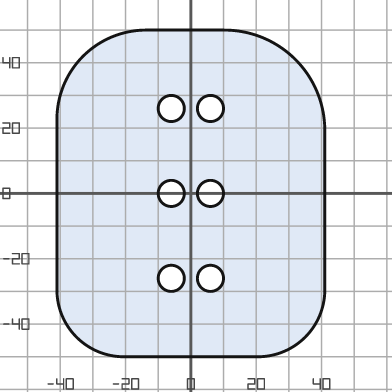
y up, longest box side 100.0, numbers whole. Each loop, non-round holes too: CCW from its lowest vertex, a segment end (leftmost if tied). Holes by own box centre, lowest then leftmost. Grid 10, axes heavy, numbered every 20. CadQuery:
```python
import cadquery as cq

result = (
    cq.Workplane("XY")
    .moveTo(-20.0, -50.0)
    .lineTo(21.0, -50.0)
    .threePointArc((35.0, -44.0), (41.0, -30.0))
    .lineTo(41.0, 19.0)
    .threePointArc((32.0, 41.0), (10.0, 50.0))
    .lineTo(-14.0, 50.0)
    .threePointArc((-33.0, 42.0), (-41.0, 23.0))
    .lineTo(-41.0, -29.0)
    .threePointArc((-35.0, -44.0), (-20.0, -50.0))
    .close()
    .moveTo(-6.0, -26.0)
    .circle(4.0)
    .moveTo(6.0, -26.0)
    .circle(4.0)
    .moveTo(-6.0, 0.0)
    .circle(4.0)
    .moveTo(6.0, 0.0)
    .circle(4.0)
    .moveTo(-6.0, 26.0)
    .circle(4.0)
    .moveTo(6.0, 26.0)
    .circle(4.0)
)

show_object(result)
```